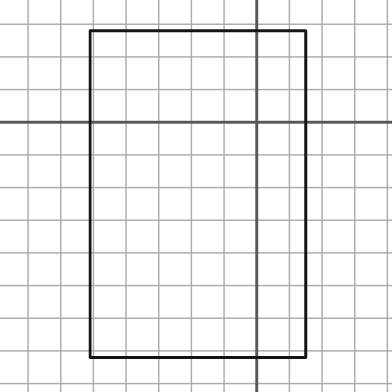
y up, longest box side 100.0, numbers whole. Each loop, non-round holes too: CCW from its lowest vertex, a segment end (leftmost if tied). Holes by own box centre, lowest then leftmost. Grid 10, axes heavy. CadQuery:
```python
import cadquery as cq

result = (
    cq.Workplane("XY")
    .moveTo(-51.0, -72.0)
    .lineTo(15.0, -72.0)
    .lineTo(15.0, 28.0)
    .lineTo(-51.0, 28.0)
    .close()
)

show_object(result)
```